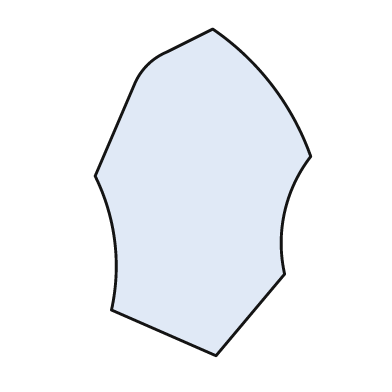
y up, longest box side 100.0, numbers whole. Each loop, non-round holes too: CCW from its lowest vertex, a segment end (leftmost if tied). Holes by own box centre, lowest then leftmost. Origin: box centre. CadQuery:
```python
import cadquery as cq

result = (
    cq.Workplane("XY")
    .moveTo(4.0, -50.0)
    .lineTo(25.0, -25.0)
    .threePointArc((25.0, -6.0), (33.0, 11.0))
    .threePointArc((21.0, 33.0), (3.0, 50.0))
    .lineTo(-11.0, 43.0)
    .threePointArc((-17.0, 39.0), (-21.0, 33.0))
    .lineTo(-33.0, 5.0)
    .threePointArc((-27.0, -15.0), (-28.0, -36.0))
    .close()
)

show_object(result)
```